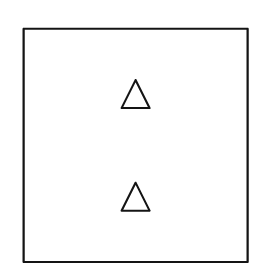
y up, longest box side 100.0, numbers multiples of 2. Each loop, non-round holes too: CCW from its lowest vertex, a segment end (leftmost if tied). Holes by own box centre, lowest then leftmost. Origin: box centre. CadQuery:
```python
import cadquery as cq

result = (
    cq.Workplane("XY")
    .moveTo(-48.0, -50.0)
    .lineTo(48.0, -50.0)
    .lineTo(48.0, 50.0)
    .lineTo(-48.0, 50.0)
    .close()
    .moveTo(-6.0, -28.0)
    .lineTo(6.0, -28.0)
    .lineTo(0.0, -16.0)
    .close()
    .moveTo(-6.0, 16.0)
    .lineTo(6.0, 16.0)
    .lineTo(0.0, 28.0)
    .close()
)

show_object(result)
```